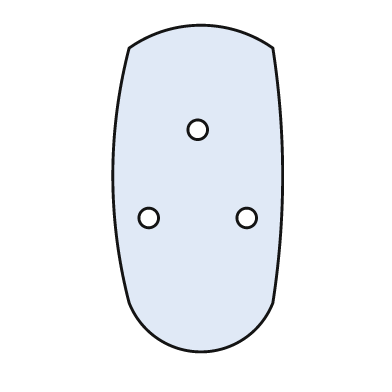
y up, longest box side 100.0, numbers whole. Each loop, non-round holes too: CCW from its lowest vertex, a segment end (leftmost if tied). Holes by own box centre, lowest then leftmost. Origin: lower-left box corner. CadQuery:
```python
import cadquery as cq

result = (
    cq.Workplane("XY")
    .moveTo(5.0, 15.0)
    .threePointArc((27.0, 0.0), (49.0, 15.0))
    .threePointArc((52.0, 54.0), (49.0, 93.0))
    .threePointArc((27.0, 100.0), (5.0, 93.0))
    .threePointArc((0.0, 54.0), (5.0, 15.0))
    .close()
    .moveTo(11.0, 41.0)
    .circle(3.0)
    .moveTo(41.0, 41.0)
    .circle(3.0)
    .moveTo(26.0, 68.0)
    .circle(3.0)
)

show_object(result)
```